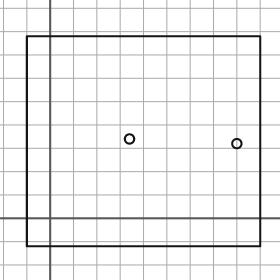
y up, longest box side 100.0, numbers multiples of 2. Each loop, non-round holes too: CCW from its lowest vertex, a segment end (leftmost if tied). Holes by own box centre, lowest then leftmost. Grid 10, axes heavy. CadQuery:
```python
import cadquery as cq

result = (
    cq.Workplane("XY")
    .moveTo(-10.0, -12.0)
    .lineTo(90.0, -12.0)
    .lineTo(90.0, 78.0)
    .lineTo(-10.0, 78.0)
    .close()
    .moveTo(80.0, 32.0)
    .circle(2.0)
    .moveTo(34.0, 34.0)
    .circle(2.0)
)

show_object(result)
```